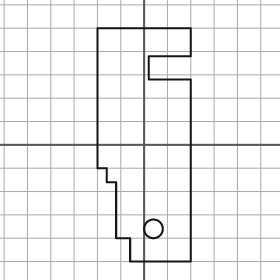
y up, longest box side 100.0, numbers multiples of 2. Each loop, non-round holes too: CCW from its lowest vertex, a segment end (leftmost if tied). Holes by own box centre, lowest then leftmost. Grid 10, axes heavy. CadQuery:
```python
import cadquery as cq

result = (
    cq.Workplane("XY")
    .moveTo(-6.0, -50.0)
    .lineTo(20.0, -50.0)
    .lineTo(20.0, 28.0)
    .lineTo(2.0, 28.0)
    .lineTo(2.0, 38.0)
    .lineTo(20.0, 38.0)
    .lineTo(20.0, 50.0)
    .lineTo(-20.0, 50.0)
    .lineTo(-20.0, -10.0)
    .lineTo(-16.0, -10.0)
    .lineTo(-16.0, -16.0)
    .lineTo(-12.0, -16.0)
    .lineTo(-12.0, -40.0)
    .lineTo(-6.0, -40.0)
    .close()
    .moveTo(4.0, -36.0)
    .circle(4.0)
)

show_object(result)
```